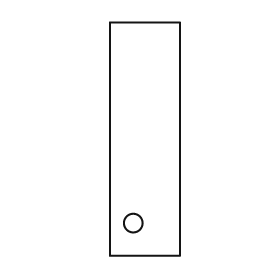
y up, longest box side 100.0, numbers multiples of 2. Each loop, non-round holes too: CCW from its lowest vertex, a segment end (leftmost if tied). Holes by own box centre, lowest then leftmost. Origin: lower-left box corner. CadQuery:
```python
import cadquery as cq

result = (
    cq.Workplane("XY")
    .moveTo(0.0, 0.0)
    .lineTo(30.0, 0.0)
    .lineTo(30.0, 100.0)
    .lineTo(0.0, 100.0)
    .close()
    .moveTo(10.0, 14.0)
    .circle(4.0)
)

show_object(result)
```